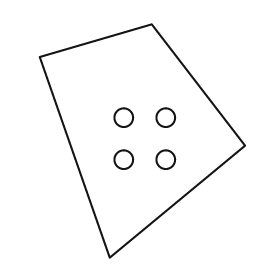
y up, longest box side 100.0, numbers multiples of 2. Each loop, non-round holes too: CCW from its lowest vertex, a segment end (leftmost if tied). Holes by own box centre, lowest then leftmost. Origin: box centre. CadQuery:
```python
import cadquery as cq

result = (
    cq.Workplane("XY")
    .moveTo(-14.0, -50.0)
    .lineTo(44.0, -2.0)
    .lineTo(4.0, 50.0)
    .lineTo(-44.0, 36.0)
    .close()
    .moveTo(-8.0, -8.0)
    .circle(4.0)
    .moveTo(10.0, -8.0)
    .circle(4.0)
    .moveTo(-8.0, 10.0)
    .circle(4.0)
    .moveTo(10.0, 10.0)
    .circle(4.0)
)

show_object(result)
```